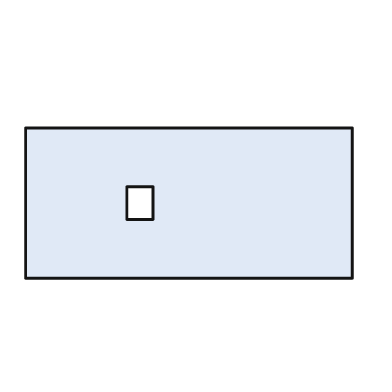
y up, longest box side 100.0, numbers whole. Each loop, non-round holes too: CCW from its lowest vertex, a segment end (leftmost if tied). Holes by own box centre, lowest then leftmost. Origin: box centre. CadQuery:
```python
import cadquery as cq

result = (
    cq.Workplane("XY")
    .moveTo(-50.0, -23.0)
    .lineTo(50.0, -23.0)
    .lineTo(50.0, 23.0)
    .lineTo(-50.0, 23.0)
    .close()
    .moveTo(-19.0, -5.0)
    .lineTo(-11.0, -5.0)
    .lineTo(-11.0, 5.0)
    .lineTo(-19.0, 5.0)
    .close()
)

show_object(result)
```